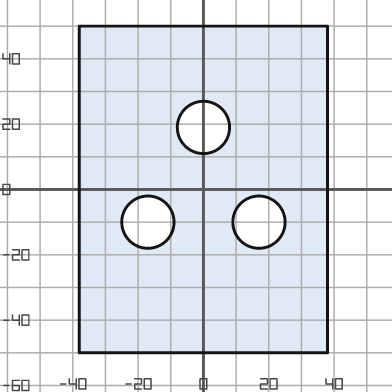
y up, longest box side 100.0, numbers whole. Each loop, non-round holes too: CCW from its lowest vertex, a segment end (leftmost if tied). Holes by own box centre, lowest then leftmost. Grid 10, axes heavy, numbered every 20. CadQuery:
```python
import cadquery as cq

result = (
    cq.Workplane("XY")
    .moveTo(-38.0, -50.0)
    .lineTo(38.0, -50.0)
    .lineTo(38.0, 50.0)
    .lineTo(-38.0, 50.0)
    .close()
    .moveTo(-17.0, -10.0)
    .circle(8.0)
    .moveTo(17.0, -10.0)
    .circle(8.0)
    .moveTo(0.0, 19.0)
    .circle(8.0)
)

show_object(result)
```